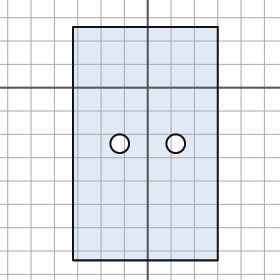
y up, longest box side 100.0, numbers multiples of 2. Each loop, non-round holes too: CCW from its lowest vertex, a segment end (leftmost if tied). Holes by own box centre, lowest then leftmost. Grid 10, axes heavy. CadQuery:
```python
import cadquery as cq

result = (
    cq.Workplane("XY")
    .moveTo(-32.0, -74.0)
    .lineTo(30.0, -74.0)
    .lineTo(30.0, 26.0)
    .lineTo(-32.0, 26.0)
    .close()
    .moveTo(-12.0, -24.0)
    .circle(4.0)
    .moveTo(12.0, -24.0)
    .circle(4.0)
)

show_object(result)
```